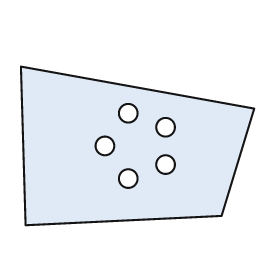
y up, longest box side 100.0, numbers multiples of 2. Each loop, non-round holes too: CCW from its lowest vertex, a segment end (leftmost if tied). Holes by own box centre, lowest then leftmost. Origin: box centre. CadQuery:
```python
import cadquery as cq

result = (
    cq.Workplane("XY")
    .moveTo(-48.0, -34.0)
    .lineTo(36.0, -30.0)
    .lineTo(50.0, 16.0)
    .lineTo(-50.0, 34.0)
    .close()
    .moveTo(-4.0, -14.0)
    .circle(4.0)
    .moveTo(12.0, -8.0)
    .circle(4.0)
    .moveTo(-14.0, 0.0)
    .circle(4.0)
    .moveTo(12.0, 8.0)
    .circle(4.0)
    .moveTo(-4.0, 14.0)
    .circle(4.0)
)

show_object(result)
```